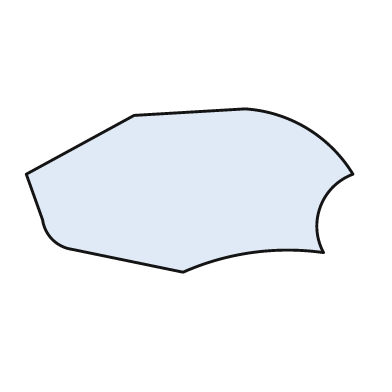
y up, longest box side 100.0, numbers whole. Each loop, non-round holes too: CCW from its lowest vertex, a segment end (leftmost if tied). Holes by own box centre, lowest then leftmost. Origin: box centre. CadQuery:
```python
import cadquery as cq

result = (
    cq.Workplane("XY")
    .moveTo(-2.0, -25.0)
    .threePointArc((19.0, -19.0), (41.0, -19.0))
    .threePointArc((40.0, -5.0), (50.0, 5.0))
    .threePointArc((36.0, 19.0), (17.0, 25.0))
    .lineTo(-17.0, 23.0)
    .lineTo(-50.0, 5.0)
    .lineTo(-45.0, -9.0)
    .threePointArc((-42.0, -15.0), (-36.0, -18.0))
    .close()
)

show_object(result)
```